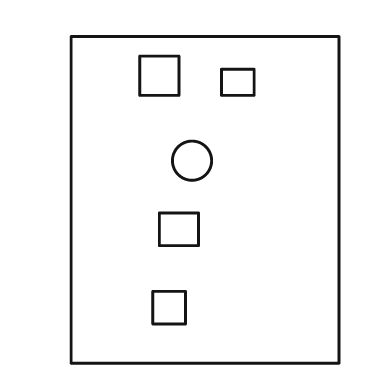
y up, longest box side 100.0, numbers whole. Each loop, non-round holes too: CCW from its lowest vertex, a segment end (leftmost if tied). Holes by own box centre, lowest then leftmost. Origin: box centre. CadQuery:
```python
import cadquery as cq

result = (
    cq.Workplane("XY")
    .moveTo(-41.0, -50.0)
    .lineTo(41.0, -50.0)
    .lineTo(41.0, 50.0)
    .lineTo(-41.0, 50.0)
    .close()
    .moveTo(-16.0, -38.0)
    .lineTo(-6.0, -38.0)
    .lineTo(-6.0, -28.0)
    .lineTo(-16.0, -28.0)
    .close()
    .moveTo(-14.0, -14.0)
    .lineTo(-2.0, -14.0)
    .lineTo(-2.0, -4.0)
    .lineTo(-14.0, -4.0)
    .close()
    .moveTo(-4.0, 12.0)
    .circle(6.0)
    .moveTo(5.0, 32.0)
    .lineTo(15.0, 32.0)
    .lineTo(15.0, 40.0)
    .lineTo(5.0, 40.0)
    .close()
    .moveTo(-20.0, 32.0)
    .lineTo(-8.0, 32.0)
    .lineTo(-8.0, 44.0)
    .lineTo(-20.0, 44.0)
    .close()
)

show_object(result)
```